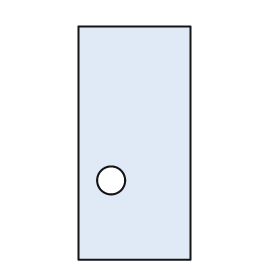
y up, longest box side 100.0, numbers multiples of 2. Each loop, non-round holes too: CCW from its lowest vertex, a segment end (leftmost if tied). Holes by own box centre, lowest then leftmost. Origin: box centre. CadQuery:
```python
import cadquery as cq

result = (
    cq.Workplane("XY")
    .moveTo(-24.0, -50.0)
    .lineTo(24.0, -50.0)
    .lineTo(24.0, 50.0)
    .lineTo(-24.0, 50.0)
    .close()
    .moveTo(-10.0, -16.0)
    .circle(6.0)
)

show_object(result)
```